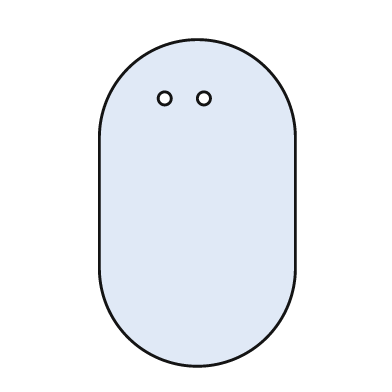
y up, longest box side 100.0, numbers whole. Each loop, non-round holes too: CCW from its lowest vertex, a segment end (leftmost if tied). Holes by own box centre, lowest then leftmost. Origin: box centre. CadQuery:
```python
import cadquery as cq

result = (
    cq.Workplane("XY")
    .moveTo(-30.0, -20.0)
    .threePointArc((0.0, -50.0), (30.0, -20.0))
    .lineTo(30.0, 20.0)
    .threePointArc((0.0, 50.0), (-30.0, 20.0))
    .close()
    .moveTo(-10.0, 32.0)
    .circle(2.0)
    .moveTo(2.0, 32.0)
    .circle(2.0)
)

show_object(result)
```